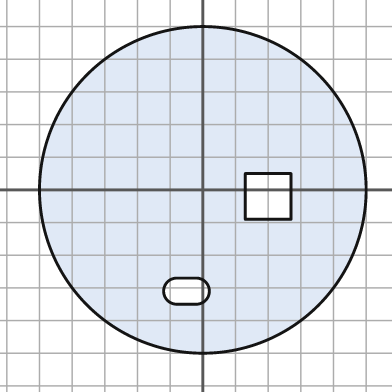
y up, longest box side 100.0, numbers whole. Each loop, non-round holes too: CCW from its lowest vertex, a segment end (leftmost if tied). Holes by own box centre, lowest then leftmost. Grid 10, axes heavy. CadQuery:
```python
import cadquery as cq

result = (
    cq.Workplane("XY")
    .moveTo(0.0, 0.0)
    .circle(50.0)
    .moveTo(-8.0, -35.0)
    .lineTo(-2.0, -35.0)
    .threePointArc((2.0, -31.0), (-2.0, -27.0))
    .lineTo(-8.0, -27.0)
    .threePointArc((-12.0, -31.0), (-8.0, -35.0))
    .close()
    .moveTo(13.0, -9.0)
    .lineTo(27.0, -9.0)
    .lineTo(27.0, 5.0)
    .lineTo(13.0, 5.0)
    .close()
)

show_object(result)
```